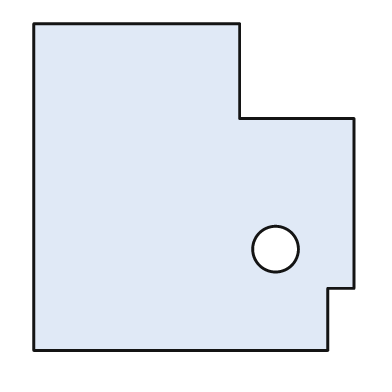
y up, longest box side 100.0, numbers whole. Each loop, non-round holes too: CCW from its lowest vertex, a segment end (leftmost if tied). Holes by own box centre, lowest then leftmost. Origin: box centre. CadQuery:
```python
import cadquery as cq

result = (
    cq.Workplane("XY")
    .moveTo(-49.0, -50.0)
    .lineTo(41.0, -50.0)
    .lineTo(41.0, -31.0)
    .lineTo(49.0, -31.0)
    .lineTo(49.0, 21.0)
    .lineTo(14.0, 21.0)
    .lineTo(14.0, 50.0)
    .lineTo(-49.0, 50.0)
    .close()
    .moveTo(25.0, -19.0)
    .circle(7.0)
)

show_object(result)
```